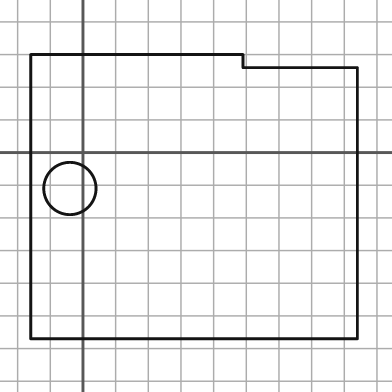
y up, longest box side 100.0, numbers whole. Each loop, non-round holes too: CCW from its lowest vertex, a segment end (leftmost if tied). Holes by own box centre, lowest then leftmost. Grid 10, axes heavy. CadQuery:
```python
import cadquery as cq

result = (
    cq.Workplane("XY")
    .moveTo(-16.0, -57.0)
    .lineTo(84.0, -57.0)
    .lineTo(84.0, 26.0)
    .lineTo(49.0, 26.0)
    .lineTo(49.0, 30.0)
    .lineTo(-16.0, 30.0)
    .close()
    .moveTo(-4.0, -11.0)
    .circle(8.0)
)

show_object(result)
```